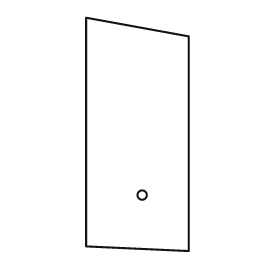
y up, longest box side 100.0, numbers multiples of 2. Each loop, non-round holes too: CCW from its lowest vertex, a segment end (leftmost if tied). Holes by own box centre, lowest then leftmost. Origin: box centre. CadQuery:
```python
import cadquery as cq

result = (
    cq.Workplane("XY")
    .moveTo(22.0, -50.0)
    .lineTo(22.0, 42.0)
    .lineTo(-22.0, 50.0)
    .lineTo(-22.0, -48.0)
    .close()
    .moveTo(2.0, -26.0)
    .circle(2.0)
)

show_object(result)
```